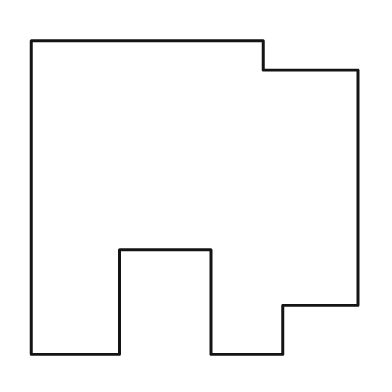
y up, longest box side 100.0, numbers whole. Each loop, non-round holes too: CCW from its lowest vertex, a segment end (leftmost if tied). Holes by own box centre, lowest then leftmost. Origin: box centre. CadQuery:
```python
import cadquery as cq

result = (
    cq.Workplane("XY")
    .moveTo(-50.0, -48.0)
    .lineTo(-23.0, -48.0)
    .lineTo(-23.0, -16.0)
    .lineTo(5.0, -16.0)
    .lineTo(5.0, -48.0)
    .lineTo(27.0, -48.0)
    .lineTo(27.0, -33.0)
    .lineTo(50.0, -33.0)
    .lineTo(50.0, 39.0)
    .lineTo(21.0, 39.0)
    .lineTo(21.0, 48.0)
    .lineTo(-50.0, 48.0)
    .close()
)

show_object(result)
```